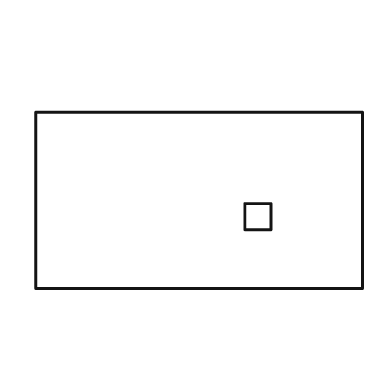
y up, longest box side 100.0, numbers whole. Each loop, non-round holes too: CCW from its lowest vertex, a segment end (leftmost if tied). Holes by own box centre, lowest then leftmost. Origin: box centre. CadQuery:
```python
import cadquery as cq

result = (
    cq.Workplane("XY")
    .moveTo(-50.0, -27.0)
    .lineTo(50.0, -27.0)
    .lineTo(50.0, 27.0)
    .lineTo(-50.0, 27.0)
    .close()
    .moveTo(14.0, -9.0)
    .lineTo(22.0, -9.0)
    .lineTo(22.0, -1.0)
    .lineTo(14.0, -1.0)
    .close()
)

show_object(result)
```